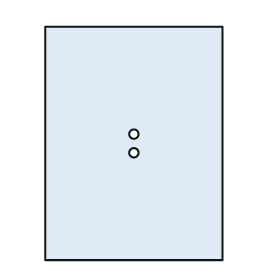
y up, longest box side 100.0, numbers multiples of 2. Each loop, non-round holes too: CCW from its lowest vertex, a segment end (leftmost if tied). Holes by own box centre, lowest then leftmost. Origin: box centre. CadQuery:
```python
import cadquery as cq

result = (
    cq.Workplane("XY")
    .moveTo(-38.0, -50.0)
    .lineTo(38.0, -50.0)
    .lineTo(38.0, 50.0)
    .lineTo(-38.0, 50.0)
    .close()
    .moveTo(0.0, -4.0)
    .circle(2.0)
    .moveTo(0.0, 4.0)
    .circle(2.0)
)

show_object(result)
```